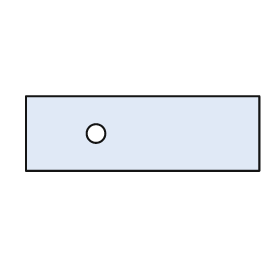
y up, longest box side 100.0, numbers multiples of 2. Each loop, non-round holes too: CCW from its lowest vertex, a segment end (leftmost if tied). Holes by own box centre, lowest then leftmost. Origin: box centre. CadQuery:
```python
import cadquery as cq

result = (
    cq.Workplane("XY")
    .moveTo(-50.0, -16.0)
    .lineTo(50.0, -16.0)
    .lineTo(50.0, 16.0)
    .lineTo(-50.0, 16.0)
    .close()
    .moveTo(-20.0, 0.0)
    .circle(4.0)
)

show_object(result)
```